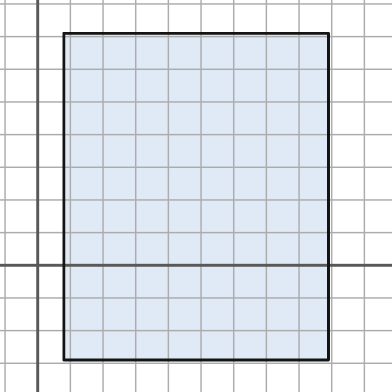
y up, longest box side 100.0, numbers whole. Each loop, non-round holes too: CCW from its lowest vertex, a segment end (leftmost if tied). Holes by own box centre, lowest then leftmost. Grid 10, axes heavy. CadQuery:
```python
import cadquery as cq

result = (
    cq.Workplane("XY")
    .moveTo(8.0, -29.0)
    .lineTo(89.0, -29.0)
    .lineTo(89.0, 71.0)
    .lineTo(8.0, 71.0)
    .close()
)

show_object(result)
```